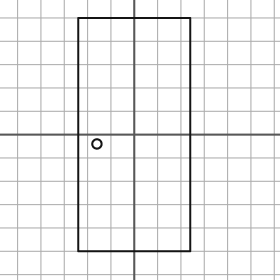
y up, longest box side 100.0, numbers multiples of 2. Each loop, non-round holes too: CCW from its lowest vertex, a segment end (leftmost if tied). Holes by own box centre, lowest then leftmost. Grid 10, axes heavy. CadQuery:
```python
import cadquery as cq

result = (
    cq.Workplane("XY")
    .moveTo(-24.0, -50.0)
    .lineTo(24.0, -50.0)
    .lineTo(24.0, 50.0)
    .lineTo(-24.0, 50.0)
    .close()
    .moveTo(-16.0, -4.0)
    .circle(2.0)
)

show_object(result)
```